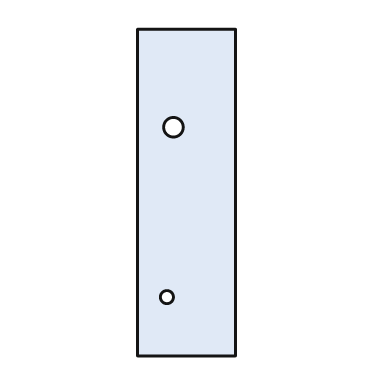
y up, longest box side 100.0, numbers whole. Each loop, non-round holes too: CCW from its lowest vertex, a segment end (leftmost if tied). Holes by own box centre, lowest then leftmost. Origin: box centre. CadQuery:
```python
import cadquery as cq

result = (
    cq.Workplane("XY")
    .moveTo(-15.0, -50.0)
    .lineTo(15.0, -50.0)
    .lineTo(15.0, 50.0)
    .lineTo(-15.0, 50.0)
    .close()
    .moveTo(-6.0, -32.0)
    .circle(2.0)
    .moveTo(-4.0, 20.0)
    .circle(3.0)
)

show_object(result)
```